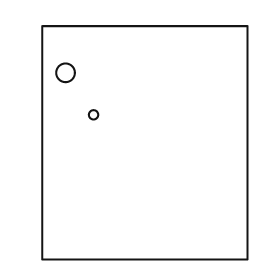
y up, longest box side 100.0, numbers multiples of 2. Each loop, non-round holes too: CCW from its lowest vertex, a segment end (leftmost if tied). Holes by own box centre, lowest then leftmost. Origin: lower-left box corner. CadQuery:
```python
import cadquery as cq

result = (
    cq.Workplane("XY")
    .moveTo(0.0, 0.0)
    .lineTo(88.0, 0.0)
    .lineTo(88.0, 100.0)
    .lineTo(0.0, 100.0)
    .close()
    .moveTo(22.0, 62.0)
    .circle(2.0)
    .moveTo(10.0, 80.0)
    .circle(4.0)
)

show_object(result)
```